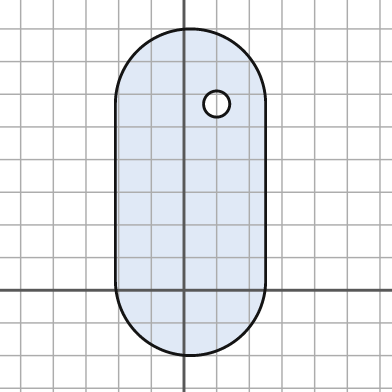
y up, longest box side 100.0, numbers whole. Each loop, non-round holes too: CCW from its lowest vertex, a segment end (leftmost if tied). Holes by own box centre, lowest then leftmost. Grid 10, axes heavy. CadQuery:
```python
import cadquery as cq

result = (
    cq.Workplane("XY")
    .moveTo(-21.0, 3.0)
    .threePointArc((2.0, -20.0), (25.0, 3.0))
    .lineTo(25.0, 57.0)
    .threePointArc((2.0, 80.0), (-21.0, 57.0))
    .close()
    .moveTo(10.0, 57.0)
    .circle(4.0)
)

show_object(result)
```